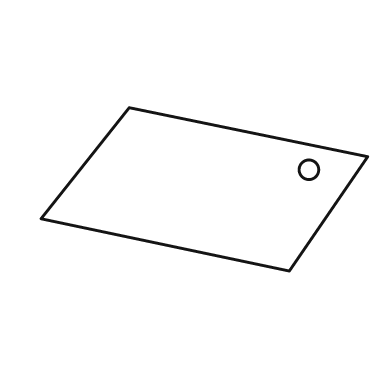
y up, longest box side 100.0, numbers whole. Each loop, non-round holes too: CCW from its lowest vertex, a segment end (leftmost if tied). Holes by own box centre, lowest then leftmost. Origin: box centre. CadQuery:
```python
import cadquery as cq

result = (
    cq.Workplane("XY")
    .moveTo(26.0, -25.0)
    .lineTo(50.0, 10.0)
    .lineTo(-23.0, 25.0)
    .lineTo(-50.0, -9.0)
    .close()
    .moveTo(32.0, 6.0)
    .circle(3.0)
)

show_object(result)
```